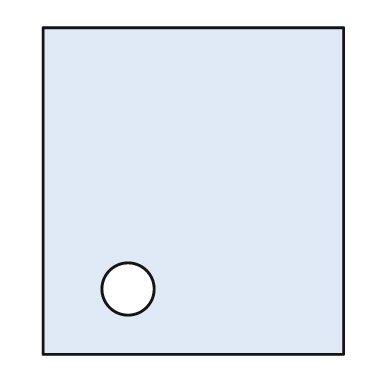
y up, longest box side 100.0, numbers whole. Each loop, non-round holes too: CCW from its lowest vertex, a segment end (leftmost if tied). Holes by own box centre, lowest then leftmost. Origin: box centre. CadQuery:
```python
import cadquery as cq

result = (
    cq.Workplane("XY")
    .moveTo(-46.0, -50.0)
    .lineTo(46.0, -50.0)
    .lineTo(46.0, 50.0)
    .lineTo(-46.0, 50.0)
    .close()
    .moveTo(-20.0, -30.0)
    .circle(8.0)
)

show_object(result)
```